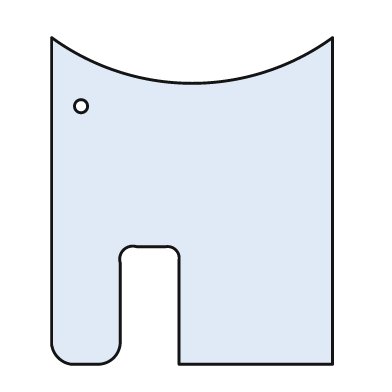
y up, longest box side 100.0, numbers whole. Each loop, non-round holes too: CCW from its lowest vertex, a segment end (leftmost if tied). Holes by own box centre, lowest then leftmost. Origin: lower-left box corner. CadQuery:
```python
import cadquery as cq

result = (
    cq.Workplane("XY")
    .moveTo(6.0, 0.0)
    .lineTo(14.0, 0.0)
    .threePointArc((19.0, 2.0), (21.0, 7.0))
    .lineTo(21.0, 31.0)
    .threePointArc((22.0, 35.0), (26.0, 36.0))
    .lineTo(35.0, 36.0)
    .threePointArc((38.0, 35.0), (39.0, 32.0))
    .lineTo(39.0, 0.0)
    .lineTo(86.0, 0.0)
    .lineTo(86.0, 100.0)
    .threePointArc((43.0, 86.0), (0.0, 100.0))
    .lineTo(0.0, 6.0)
    .threePointArc((2.0, 2.0), (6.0, 0.0))
    .close()
    .moveTo(9.0, 79.0)
    .circle(2.0)
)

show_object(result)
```